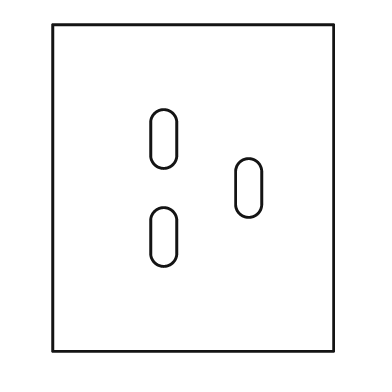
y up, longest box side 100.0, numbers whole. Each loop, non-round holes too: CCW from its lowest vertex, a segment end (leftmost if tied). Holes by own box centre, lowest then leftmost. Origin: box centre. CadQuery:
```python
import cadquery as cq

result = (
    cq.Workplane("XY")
    .moveTo(-43.0, -50.0)
    .lineTo(43.0, -50.0)
    .lineTo(43.0, 50.0)
    .lineTo(-43.0, 50.0)
    .close()
    .moveTo(-13.0, -20.0)
    .threePointArc((-9.0, -24.0), (-5.0, -20.0))
    .lineTo(-5.0, -10.0)
    .threePointArc((-9.0, -6.0), (-13.0, -10.0))
    .close()
    .moveTo(13.0, -5.0)
    .threePointArc((17.0, -9.0), (21.0, -5.0))
    .lineTo(21.0, 5.0)
    .threePointArc((17.0, 9.0), (13.0, 5.0))
    .close()
    .moveTo(-13.0, 10.0)
    .threePointArc((-9.0, 6.0), (-5.0, 10.0))
    .lineTo(-5.0, 20.0)
    .threePointArc((-9.0, 24.0), (-13.0, 20.0))
    .close()
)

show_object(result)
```